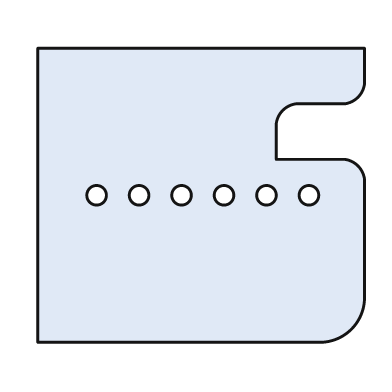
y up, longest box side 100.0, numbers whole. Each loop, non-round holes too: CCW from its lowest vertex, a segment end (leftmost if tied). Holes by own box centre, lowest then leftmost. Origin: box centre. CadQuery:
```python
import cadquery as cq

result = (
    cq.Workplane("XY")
    .moveTo(-50.0, -45.0)
    .lineTo(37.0, -45.0)
    .threePointArc((46.0, -41.0), (50.0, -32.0))
    .lineTo(50.0, 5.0)
    .threePointArc((48.0, 9.0), (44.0, 11.0))
    .lineTo(23.0, 11.0)
    .lineTo(23.0, 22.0)
    .threePointArc((25.0, 26.0), (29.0, 28.0))
    .lineTo(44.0, 28.0)
    .threePointArc((48.0, 30.0), (50.0, 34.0))
    .lineTo(50.0, 45.0)
    .lineTo(-50.0, 45.0)
    .close()
    .moveTo(-32.0, 0.0)
    .circle(3.0)
    .moveTo(-19.0, 0.0)
    .circle(3.0)
    .moveTo(-6.0, 0.0)
    .circle(3.0)
    .moveTo(7.0, 0.0)
    .circle(3.0)
    .moveTo(20.0, 0.0)
    .circle(3.0)
    .moveTo(33.0, 0.0)
    .circle(3.0)
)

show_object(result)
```